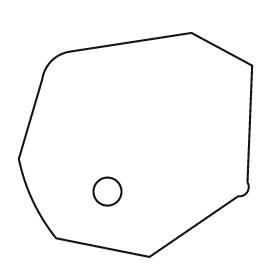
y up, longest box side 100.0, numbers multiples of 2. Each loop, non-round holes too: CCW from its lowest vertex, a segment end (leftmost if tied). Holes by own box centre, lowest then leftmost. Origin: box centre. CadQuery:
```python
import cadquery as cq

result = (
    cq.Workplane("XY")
    .moveTo(6.0, -48.0)
    .lineTo(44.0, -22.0)
    .threePointArc((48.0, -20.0), (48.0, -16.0))
    .lineTo(50.0, 34.0)
    .lineTo(24.0, 48.0)
    .lineTo(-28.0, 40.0)
    .threePointArc((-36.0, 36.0), (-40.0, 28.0))
    .lineTo(-50.0, -6.0)
    .threePointArc((-44.0, -24.0), (-34.0, -40.0))
    .close()
    .moveTo(-12.0, -20.0)
    .circle(6.0)
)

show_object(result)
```